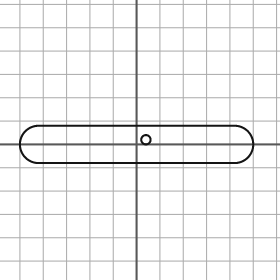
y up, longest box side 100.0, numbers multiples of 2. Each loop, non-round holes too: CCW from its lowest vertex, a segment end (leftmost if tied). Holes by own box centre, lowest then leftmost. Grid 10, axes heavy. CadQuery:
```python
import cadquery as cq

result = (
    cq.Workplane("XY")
    .moveTo(-42.0, -8.0)
    .lineTo(42.0, -8.0)
    .threePointArc((50.0, 0.0), (42.0, 8.0))
    .lineTo(-42.0, 8.0)
    .threePointArc((-50.0, 0.0), (-42.0, -8.0))
    .close()
    .moveTo(4.0, 2.0)
    .circle(2.0)
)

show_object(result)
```